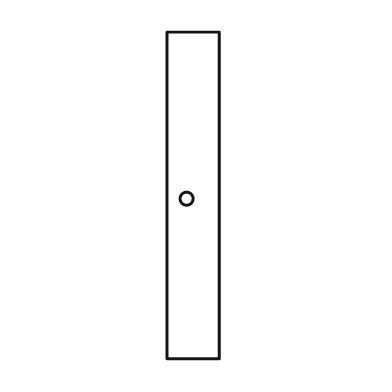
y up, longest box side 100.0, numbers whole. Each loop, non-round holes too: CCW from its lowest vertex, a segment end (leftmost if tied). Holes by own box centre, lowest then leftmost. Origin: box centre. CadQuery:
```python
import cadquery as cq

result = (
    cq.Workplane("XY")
    .moveTo(-8.0, -50.0)
    .lineTo(8.0, -50.0)
    .lineTo(8.0, 50.0)
    .lineTo(-8.0, 50.0)
    .close()
    .moveTo(-2.0, -1.0)
    .circle(2.0)
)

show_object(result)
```